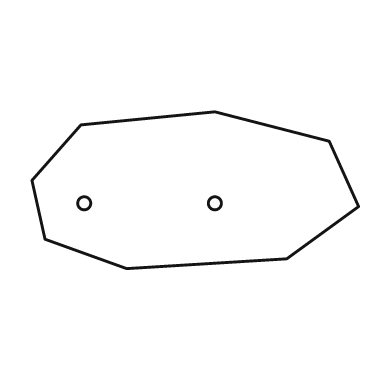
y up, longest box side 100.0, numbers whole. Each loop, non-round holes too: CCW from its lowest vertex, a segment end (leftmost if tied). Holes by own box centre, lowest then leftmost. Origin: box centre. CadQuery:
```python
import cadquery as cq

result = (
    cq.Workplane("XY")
    .moveTo(-21.0, -24.0)
    .lineTo(28.0, -21.0)
    .lineTo(50.0, -5.0)
    .lineTo(41.0, 15.0)
    .lineTo(6.0, 24.0)
    .lineTo(-35.0, 20.0)
    .lineTo(-50.0, 3.0)
    .lineTo(-46.0, -15.0)
    .close()
    .moveTo(-34.0, -4.0)
    .circle(2.0)
    .moveTo(6.0, -4.0)
    .circle(2.0)
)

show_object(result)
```